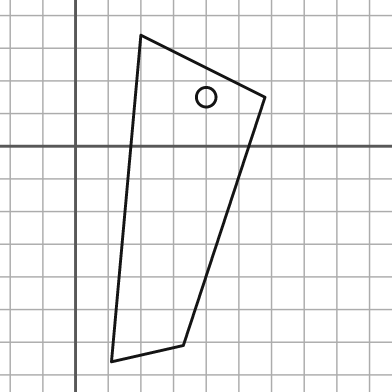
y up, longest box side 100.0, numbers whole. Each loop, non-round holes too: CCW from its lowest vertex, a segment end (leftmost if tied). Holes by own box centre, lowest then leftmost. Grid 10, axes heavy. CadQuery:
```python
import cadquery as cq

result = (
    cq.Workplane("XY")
    .moveTo(11.0, -66.0)
    .lineTo(33.0, -61.0)
    .lineTo(58.0, 15.0)
    .lineTo(20.0, 34.0)
    .close()
    .moveTo(40.0, 15.0)
    .circle(3.0)
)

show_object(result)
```